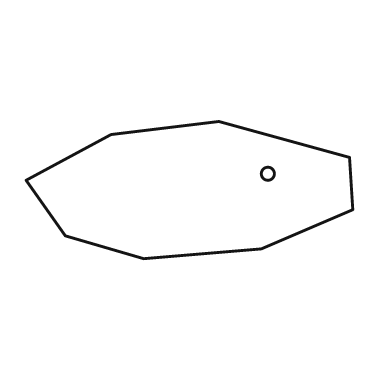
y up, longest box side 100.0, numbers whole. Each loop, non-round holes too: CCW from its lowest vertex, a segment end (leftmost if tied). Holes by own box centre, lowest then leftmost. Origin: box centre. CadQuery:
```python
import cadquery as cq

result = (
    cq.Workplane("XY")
    .moveTo(-14.0, -21.0)
    .lineTo(22.0, -18.0)
    .lineTo(50.0, -6.0)
    .lineTo(49.0, 10.0)
    .lineTo(9.0, 21.0)
    .lineTo(-24.0, 17.0)
    .lineTo(-50.0, 3.0)
    .lineTo(-38.0, -14.0)
    .close()
    .moveTo(24.0, 5.0)
    .circle(2.0)
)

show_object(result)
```